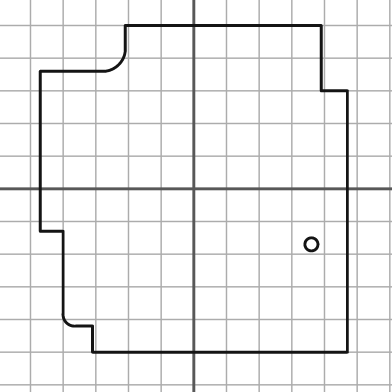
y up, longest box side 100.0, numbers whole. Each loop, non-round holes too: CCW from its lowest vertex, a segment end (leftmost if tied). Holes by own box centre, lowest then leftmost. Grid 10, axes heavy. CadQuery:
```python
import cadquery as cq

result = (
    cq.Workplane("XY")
    .moveTo(-31.0, -50.0)
    .lineTo(47.0, -50.0)
    .lineTo(47.0, 30.0)
    .lineTo(39.0, 30.0)
    .lineTo(39.0, 50.0)
    .lineTo(-21.0, 50.0)
    .lineTo(-21.0, 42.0)
    .threePointArc((-23.0, 38.0), (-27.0, 36.0))
    .lineTo(-47.0, 36.0)
    .lineTo(-47.0, -13.0)
    .lineTo(-40.0, -13.0)
    .lineTo(-40.0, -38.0)
    .threePointArc((-39.0, -41.0), (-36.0, -42.0))
    .lineTo(-31.0, -42.0)
    .close()
    .moveTo(36.0, -17.0)
    .circle(2.0)
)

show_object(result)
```